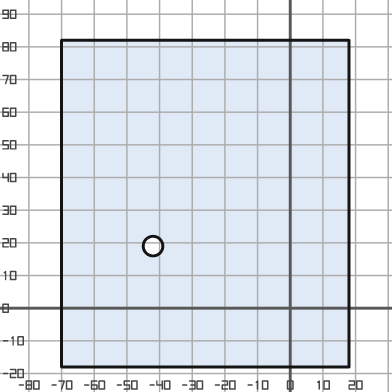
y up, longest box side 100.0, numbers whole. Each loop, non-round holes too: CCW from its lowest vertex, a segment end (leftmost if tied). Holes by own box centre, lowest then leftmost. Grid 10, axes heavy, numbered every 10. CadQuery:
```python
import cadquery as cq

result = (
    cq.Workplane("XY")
    .moveTo(-70.0, -18.0)
    .lineTo(18.0, -18.0)
    .lineTo(18.0, 82.0)
    .lineTo(-70.0, 82.0)
    .close()
    .moveTo(-42.0, 19.0)
    .circle(3.0)
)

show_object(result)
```